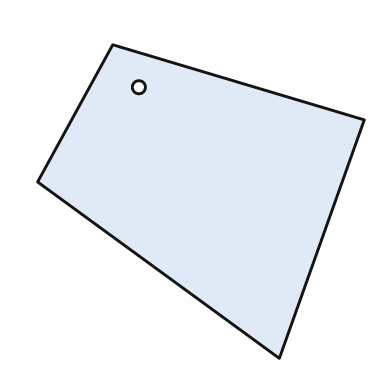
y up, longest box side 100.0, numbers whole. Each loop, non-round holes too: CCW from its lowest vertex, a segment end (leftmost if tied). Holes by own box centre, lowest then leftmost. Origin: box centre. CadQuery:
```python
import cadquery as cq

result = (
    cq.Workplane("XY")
    .moveTo(24.0, -48.0)
    .lineTo(50.0, 25.0)
    .lineTo(-27.0, 48.0)
    .lineTo(-50.0, 6.0)
    .close()
    .moveTo(-19.0, 35.0)
    .circle(2.0)
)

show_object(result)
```